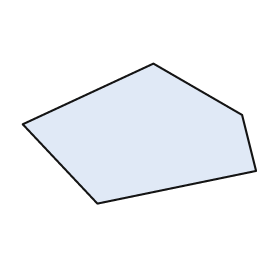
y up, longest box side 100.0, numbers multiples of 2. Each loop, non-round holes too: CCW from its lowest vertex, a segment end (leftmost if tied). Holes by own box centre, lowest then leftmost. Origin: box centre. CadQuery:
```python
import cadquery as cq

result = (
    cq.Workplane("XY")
    .moveTo(-18.0, -30.0)
    .lineTo(50.0, -16.0)
    .lineTo(44.0, 8.0)
    .lineTo(6.0, 30.0)
    .lineTo(-50.0, 4.0)
    .close()
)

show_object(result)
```